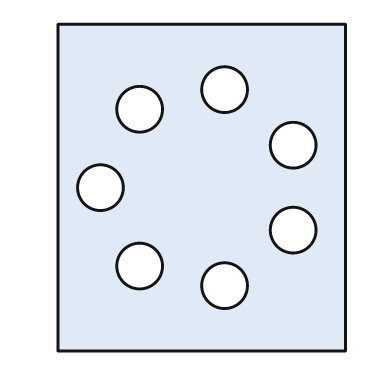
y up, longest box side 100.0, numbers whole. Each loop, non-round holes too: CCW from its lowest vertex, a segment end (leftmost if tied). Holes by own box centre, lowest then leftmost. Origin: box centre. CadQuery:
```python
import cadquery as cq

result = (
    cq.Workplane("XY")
    .moveTo(-44.0, -50.0)
    .lineTo(44.0, -50.0)
    .lineTo(44.0, 50.0)
    .lineTo(-44.0, 50.0)
    .close()
    .moveTo(7.0, -30.0)
    .circle(7.0)
    .moveTo(-19.0, -24.0)
    .circle(7.0)
    .moveTo(28.0, -13.0)
    .circle(7.0)
    .moveTo(-31.0, 0.0)
    .circle(7.0)
    .moveTo(28.0, 13.0)
    .circle(7.0)
    .moveTo(-19.0, 24.0)
    .circle(7.0)
    .moveTo(7.0, 30.0)
    .circle(7.0)
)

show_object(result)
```